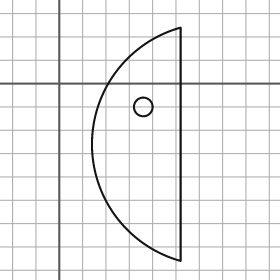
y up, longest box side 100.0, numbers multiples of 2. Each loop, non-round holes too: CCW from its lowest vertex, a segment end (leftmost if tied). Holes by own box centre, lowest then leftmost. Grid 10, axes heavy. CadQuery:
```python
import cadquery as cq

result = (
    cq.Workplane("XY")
    .moveTo(52.0, -76.0)
    .lineTo(52.0, 24.0)
    .threePointArc((14.0, -26.0), (52.0, -76.0))
    .close()
    .moveTo(36.0, -10.0)
    .circle(4.0)
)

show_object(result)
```